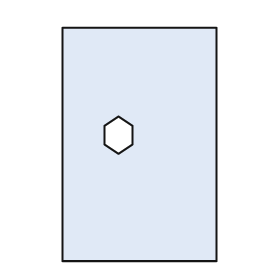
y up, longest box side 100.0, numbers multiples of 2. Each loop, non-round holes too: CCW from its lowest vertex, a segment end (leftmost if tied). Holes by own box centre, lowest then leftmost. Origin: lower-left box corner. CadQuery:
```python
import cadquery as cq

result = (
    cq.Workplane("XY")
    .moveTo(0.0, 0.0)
    .lineTo(66.0, 0.0)
    .lineTo(66.0, 100.0)
    .lineTo(0.0, 100.0)
    .close()
    .moveTo(24.0, 46.0)
    .lineTo(30.0, 50.0)
    .lineTo(30.0, 58.0)
    .lineTo(24.0, 62.0)
    .lineTo(18.0, 58.0)
    .lineTo(18.0, 50.0)
    .close()
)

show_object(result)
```